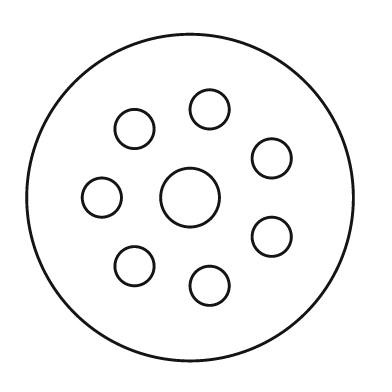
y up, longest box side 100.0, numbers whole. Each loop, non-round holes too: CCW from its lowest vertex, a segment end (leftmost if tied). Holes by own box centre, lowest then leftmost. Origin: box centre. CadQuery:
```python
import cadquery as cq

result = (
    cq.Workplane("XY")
    .moveTo(0.0, 0.0)
    .circle(50.0)
    .moveTo(6.0, -27.0)
    .circle(6.0)
    .moveTo(-17.0, -21.0)
    .circle(6.0)
    .moveTo(25.0, -12.0)
    .circle(6.0)
    .moveTo(-27.0, 0.0)
    .circle(6.0)
    .moveTo(0.0, 0.0)
    .circle(9.0)
    .moveTo(25.0, 12.0)
    .circle(6.0)
    .moveTo(-17.0, 21.0)
    .circle(6.0)
    .moveTo(6.0, 27.0)
    .circle(6.0)
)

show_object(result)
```